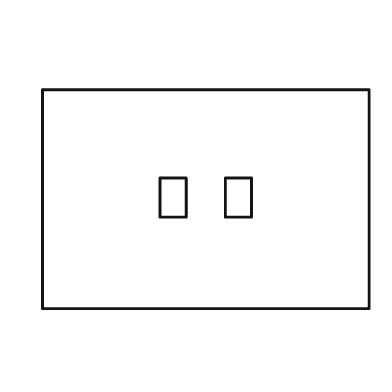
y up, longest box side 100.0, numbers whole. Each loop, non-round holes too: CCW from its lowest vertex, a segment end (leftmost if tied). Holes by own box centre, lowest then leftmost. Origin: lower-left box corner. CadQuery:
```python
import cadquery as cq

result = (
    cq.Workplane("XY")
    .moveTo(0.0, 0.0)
    .lineTo(100.0, 0.0)
    .lineTo(100.0, 67.0)
    .lineTo(0.0, 67.0)
    .close()
    .moveTo(36.0, 28.0)
    .lineTo(44.0, 28.0)
    .lineTo(44.0, 40.0)
    .lineTo(36.0, 40.0)
    .close()
    .moveTo(56.0, 28.0)
    .lineTo(64.0, 28.0)
    .lineTo(64.0, 40.0)
    .lineTo(56.0, 40.0)
    .close()
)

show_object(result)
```